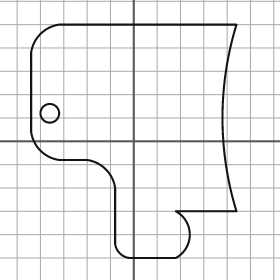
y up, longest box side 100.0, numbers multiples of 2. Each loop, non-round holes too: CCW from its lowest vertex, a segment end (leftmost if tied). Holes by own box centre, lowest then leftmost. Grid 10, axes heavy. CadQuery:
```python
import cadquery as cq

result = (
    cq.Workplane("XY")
    .moveTo(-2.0, -50.0)
    .lineTo(18.0, -50.0)
    .threePointArc((24.0, -40.0), (18.0, -30.0))
    .lineTo(44.0, -30.0)
    .threePointArc((38.0, 10.0), (44.0, 50.0))
    .lineTo(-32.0, 50.0)
    .threePointArc((-40.0, 46.0), (-44.0, 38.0))
    .lineTo(-44.0, 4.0)
    .threePointArc((-40.0, -4.0), (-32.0, -8.0))
    .lineTo(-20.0, -8.0)
    .threePointArc((-12.0, -12.0), (-8.0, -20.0))
    .lineTo(-8.0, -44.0)
    .threePointArc((-6.0, -48.0), (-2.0, -50.0))
    .close()
    .moveTo(-36.0, 12.0)
    .circle(4.0)
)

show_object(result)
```